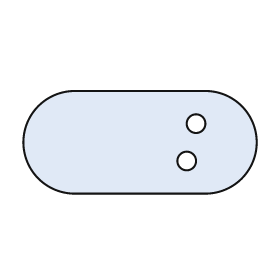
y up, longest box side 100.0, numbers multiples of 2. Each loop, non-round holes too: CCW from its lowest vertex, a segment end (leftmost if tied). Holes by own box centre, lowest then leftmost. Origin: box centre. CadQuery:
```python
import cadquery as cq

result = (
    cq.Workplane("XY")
    .moveTo(-28.0, -22.0)
    .lineTo(28.0, -22.0)
    .threePointArc((50.0, 0.0), (28.0, 22.0))
    .lineTo(-28.0, 22.0)
    .threePointArc((-50.0, 0.0), (-28.0, -22.0))
    .close()
    .moveTo(20.0, -8.0)
    .circle(4.0)
    .moveTo(24.0, 8.0)
    .circle(4.0)
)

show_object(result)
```